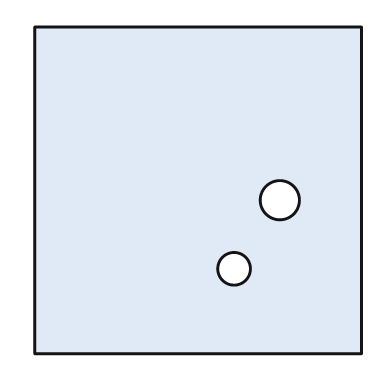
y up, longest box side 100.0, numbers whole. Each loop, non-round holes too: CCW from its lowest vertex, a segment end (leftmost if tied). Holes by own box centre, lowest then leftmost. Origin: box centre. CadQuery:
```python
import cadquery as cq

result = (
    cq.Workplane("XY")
    .moveTo(-50.0, -50.0)
    .lineTo(50.0, -50.0)
    .lineTo(50.0, 50.0)
    .lineTo(-50.0, 50.0)
    .close()
    .moveTo(11.0, -24.0)
    .circle(5.0)
    .moveTo(25.0, -3.0)
    .circle(6.0)
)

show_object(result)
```